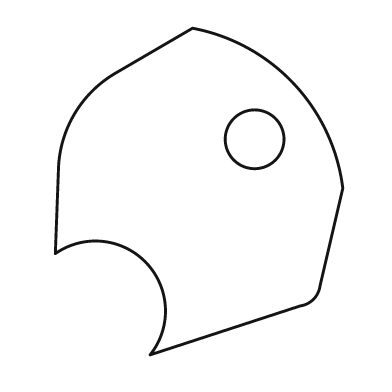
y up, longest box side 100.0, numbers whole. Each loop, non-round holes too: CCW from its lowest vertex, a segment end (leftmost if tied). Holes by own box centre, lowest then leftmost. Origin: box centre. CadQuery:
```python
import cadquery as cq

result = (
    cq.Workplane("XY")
    .moveTo(-15.0, -50.0)
    .lineTo(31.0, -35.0)
    .threePointArc((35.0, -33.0), (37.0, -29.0))
    .lineTo(44.0, 1.0)
    .threePointArc((29.0, 33.0), (-2.0, 50.0))
    .lineTo(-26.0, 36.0)
    .threePointArc((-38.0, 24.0), (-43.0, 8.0))
    .lineTo(-44.0, -19.0)
    .threePointArc((-16.0, -22.0), (-15.0, -50.0))
    .close()
    .moveTo(17.0, 16.0)
    .circle(9.0)
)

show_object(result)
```